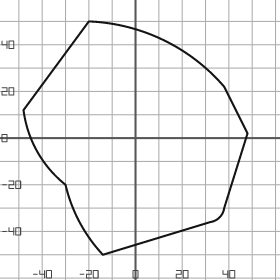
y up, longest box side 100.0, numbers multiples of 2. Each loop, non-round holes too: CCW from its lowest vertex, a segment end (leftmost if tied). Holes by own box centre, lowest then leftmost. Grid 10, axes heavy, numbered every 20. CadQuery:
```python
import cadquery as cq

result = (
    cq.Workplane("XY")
    .moveTo(-14.0, -50.0)
    .lineTo(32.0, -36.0)
    .threePointArc((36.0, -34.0), (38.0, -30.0))
    .lineTo(48.0, 2.0)
    .lineTo(38.0, 22.0)
    .threePointArc((12.0, 42.0), (-20.0, 50.0))
    .lineTo(-48.0, 12.0)
    .threePointArc((-42.0, -6.0), (-30.0, -20.0))
    .threePointArc((-24.0, -36.0), (-14.0, -50.0))
    .close()
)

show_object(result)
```